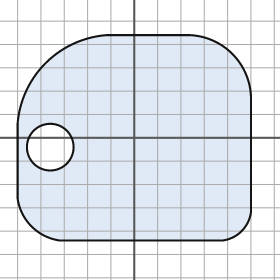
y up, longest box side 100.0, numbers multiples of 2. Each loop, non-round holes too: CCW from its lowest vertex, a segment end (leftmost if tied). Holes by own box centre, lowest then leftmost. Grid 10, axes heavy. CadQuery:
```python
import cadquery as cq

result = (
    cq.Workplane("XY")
    .moveTo(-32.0, -44.0)
    .lineTo(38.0, -44.0)
    .threePointArc((46.0, -40.0), (50.0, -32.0))
    .lineTo(50.0, 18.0)
    .threePointArc((42.0, 36.0), (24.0, 44.0))
    .lineTo(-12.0, 44.0)
    .threePointArc((-38.0, 32.0), (-50.0, 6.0))
    .lineTo(-50.0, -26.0)
    .threePointArc((-44.0, -38.0), (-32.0, -44.0))
    .close()
    .moveTo(-36.0, -4.0)
    .circle(10.0)
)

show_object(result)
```